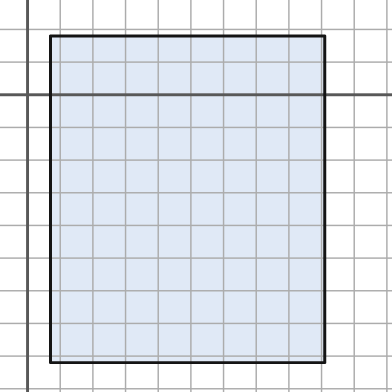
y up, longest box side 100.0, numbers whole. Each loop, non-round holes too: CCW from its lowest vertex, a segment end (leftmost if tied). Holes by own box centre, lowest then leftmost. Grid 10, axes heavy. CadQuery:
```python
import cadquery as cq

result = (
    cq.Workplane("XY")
    .moveTo(7.0, -82.0)
    .lineTo(91.0, -82.0)
    .lineTo(91.0, 18.0)
    .lineTo(7.0, 18.0)
    .close()
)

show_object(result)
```